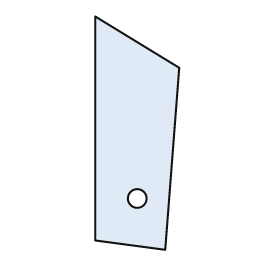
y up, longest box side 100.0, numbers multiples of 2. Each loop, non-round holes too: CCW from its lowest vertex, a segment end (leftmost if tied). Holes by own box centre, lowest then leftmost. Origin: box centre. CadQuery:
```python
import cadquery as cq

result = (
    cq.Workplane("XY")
    .moveTo(12.0, -50.0)
    .lineTo(18.0, 28.0)
    .lineTo(-18.0, 50.0)
    .lineTo(-18.0, -46.0)
    .close()
    .moveTo(0.0, -28.0)
    .circle(4.0)
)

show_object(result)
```